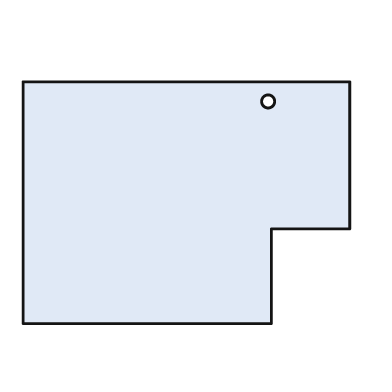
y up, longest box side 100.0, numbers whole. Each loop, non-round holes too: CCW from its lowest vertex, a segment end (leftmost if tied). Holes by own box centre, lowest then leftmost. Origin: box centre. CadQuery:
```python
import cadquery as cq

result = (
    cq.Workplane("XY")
    .moveTo(-50.0, -37.0)
    .lineTo(26.0, -37.0)
    .lineTo(26.0, -8.0)
    .lineTo(50.0, -8.0)
    .lineTo(50.0, 37.0)
    .lineTo(-50.0, 37.0)
    .close()
    .moveTo(25.0, 31.0)
    .circle(2.0)
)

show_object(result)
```